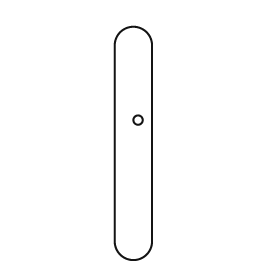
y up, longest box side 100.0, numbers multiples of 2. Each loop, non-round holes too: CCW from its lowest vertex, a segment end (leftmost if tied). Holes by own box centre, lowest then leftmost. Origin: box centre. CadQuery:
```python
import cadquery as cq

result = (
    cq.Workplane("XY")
    .moveTo(-8.0, -42.0)
    .threePointArc((0.0, -50.0), (8.0, -42.0))
    .lineTo(8.0, 42.0)
    .threePointArc((0.0, 50.0), (-8.0, 42.0))
    .close()
    .moveTo(2.0, 10.0)
    .circle(2.0)
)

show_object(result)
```